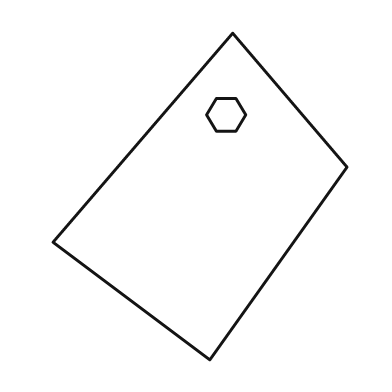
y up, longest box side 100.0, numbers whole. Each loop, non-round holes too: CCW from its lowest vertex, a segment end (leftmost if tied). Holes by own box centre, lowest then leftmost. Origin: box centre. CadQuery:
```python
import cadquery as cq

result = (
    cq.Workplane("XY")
    .moveTo(3.0, -50.0)
    .lineTo(45.0, 9.0)
    .lineTo(10.0, 50.0)
    .lineTo(-45.0, -14.0)
    .close()
    .moveTo(5.0, 20.0)
    .lineTo(11.0, 20.0)
    .lineTo(14.0, 25.0)
    .lineTo(11.0, 30.0)
    .lineTo(5.0, 30.0)
    .lineTo(2.0, 25.0)
    .close()
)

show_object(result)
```